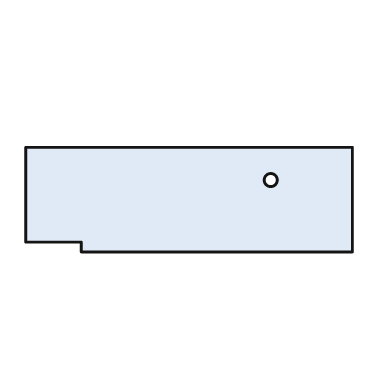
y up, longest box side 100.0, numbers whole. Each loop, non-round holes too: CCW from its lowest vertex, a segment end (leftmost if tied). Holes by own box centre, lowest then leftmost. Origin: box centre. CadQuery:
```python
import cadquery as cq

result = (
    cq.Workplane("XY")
    .moveTo(-33.0, -16.0)
    .lineTo(50.0, -16.0)
    .lineTo(50.0, 16.0)
    .lineTo(-50.0, 16.0)
    .lineTo(-50.0, -13.0)
    .lineTo(-33.0, -13.0)
    .close()
    .moveTo(25.0, 6.0)
    .circle(2.0)
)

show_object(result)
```